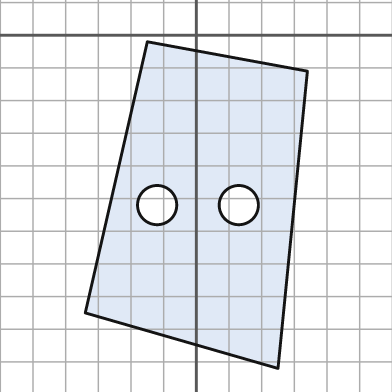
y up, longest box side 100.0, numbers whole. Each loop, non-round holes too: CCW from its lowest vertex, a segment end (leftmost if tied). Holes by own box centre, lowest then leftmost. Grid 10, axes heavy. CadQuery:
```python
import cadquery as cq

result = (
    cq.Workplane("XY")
    .moveTo(25.0, -102.0)
    .lineTo(34.0, -11.0)
    .lineTo(-15.0, -2.0)
    .lineTo(-34.0, -85.0)
    .close()
    .moveTo(-12.0, -52.0)
    .circle(6.0)
    .moveTo(13.0, -52.0)
    .circle(6.0)
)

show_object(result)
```